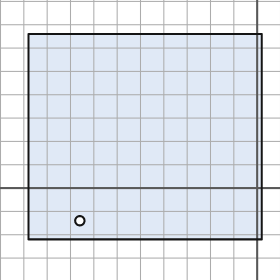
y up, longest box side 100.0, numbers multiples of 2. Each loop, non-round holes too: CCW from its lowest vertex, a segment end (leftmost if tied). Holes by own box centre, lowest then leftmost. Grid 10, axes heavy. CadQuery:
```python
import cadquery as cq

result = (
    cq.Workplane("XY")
    .moveTo(-98.0, -22.0)
    .lineTo(2.0, -22.0)
    .lineTo(2.0, 66.0)
    .lineTo(-98.0, 66.0)
    .close()
    .moveTo(-76.0, -14.0)
    .circle(2.0)
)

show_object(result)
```